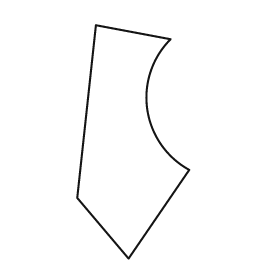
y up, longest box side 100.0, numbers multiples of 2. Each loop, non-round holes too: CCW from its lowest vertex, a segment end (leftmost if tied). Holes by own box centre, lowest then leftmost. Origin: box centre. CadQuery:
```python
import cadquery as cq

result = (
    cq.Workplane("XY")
    .moveTo(-2.0, -50.0)
    .lineTo(24.0, -12.0)
    .threePointArc((6.0, 14.0), (16.0, 44.0))
    .lineTo(-16.0, 50.0)
    .lineTo(-24.0, -24.0)
    .close()
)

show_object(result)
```